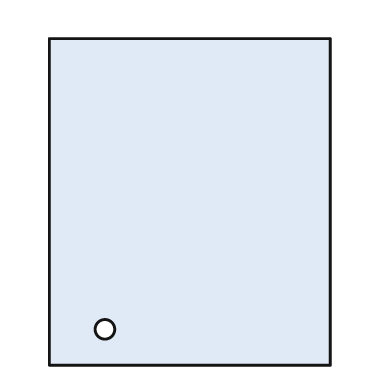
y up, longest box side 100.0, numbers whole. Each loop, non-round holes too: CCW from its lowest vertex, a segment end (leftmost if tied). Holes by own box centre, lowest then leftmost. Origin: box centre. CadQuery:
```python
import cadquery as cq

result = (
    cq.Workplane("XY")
    .moveTo(-43.0, -50.0)
    .lineTo(43.0, -50.0)
    .lineTo(43.0, 50.0)
    .lineTo(-43.0, 50.0)
    .close()
    .moveTo(-26.0, -39.0)
    .circle(3.0)
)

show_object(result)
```